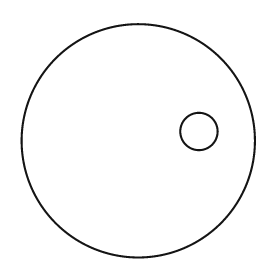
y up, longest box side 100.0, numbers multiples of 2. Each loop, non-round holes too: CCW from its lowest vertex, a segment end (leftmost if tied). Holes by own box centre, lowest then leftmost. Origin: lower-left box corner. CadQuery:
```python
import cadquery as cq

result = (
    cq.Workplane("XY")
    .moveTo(50.0, 50.0)
    .circle(50.0)
    .moveTo(76.0, 54.0)
    .circle(8.0)
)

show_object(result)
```